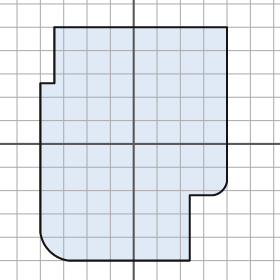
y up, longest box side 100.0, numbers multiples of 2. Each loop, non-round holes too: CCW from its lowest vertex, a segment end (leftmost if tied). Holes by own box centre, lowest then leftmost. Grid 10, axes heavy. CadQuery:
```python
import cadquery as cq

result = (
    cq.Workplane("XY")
    .moveTo(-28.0, -50.0)
    .lineTo(24.0, -50.0)
    .lineTo(24.0, -22.0)
    .lineTo(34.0, -22.0)
    .threePointArc((38.0, -20.0), (40.0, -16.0))
    .lineTo(40.0, 50.0)
    .lineTo(-34.0, 50.0)
    .lineTo(-34.0, 26.0)
    .lineTo(-40.0, 26.0)
    .lineTo(-40.0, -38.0)
    .threePointArc((-36.0, -46.0), (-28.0, -50.0))
    .close()
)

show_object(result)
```